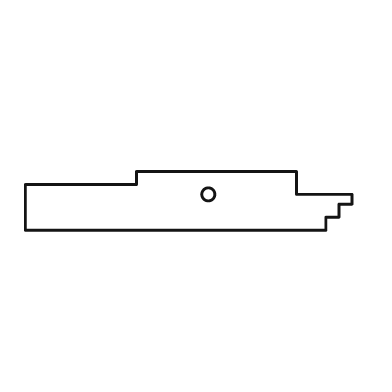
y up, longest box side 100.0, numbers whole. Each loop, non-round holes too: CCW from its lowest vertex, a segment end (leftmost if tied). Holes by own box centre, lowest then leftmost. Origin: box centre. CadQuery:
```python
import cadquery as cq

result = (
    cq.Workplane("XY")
    .moveTo(-50.0, -9.0)
    .lineTo(42.0, -9.0)
    .lineTo(42.0, -5.0)
    .lineTo(46.0, -5.0)
    .lineTo(46.0, -1.0)
    .lineTo(50.0, -1.0)
    .lineTo(50.0, 2.0)
    .lineTo(33.0, 2.0)
    .lineTo(33.0, 9.0)
    .lineTo(-16.0, 9.0)
    .lineTo(-16.0, 5.0)
    .lineTo(-50.0, 5.0)
    .close()
    .moveTo(6.0, 2.0)
    .circle(2.0)
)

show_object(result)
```